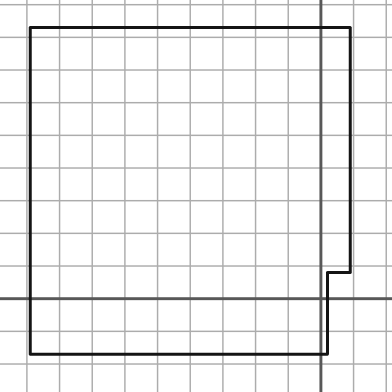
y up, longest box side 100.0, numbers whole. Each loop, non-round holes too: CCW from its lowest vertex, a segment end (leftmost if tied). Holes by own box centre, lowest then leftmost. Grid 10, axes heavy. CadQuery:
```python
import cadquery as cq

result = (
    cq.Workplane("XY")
    .moveTo(-89.0, -17.0)
    .lineTo(2.0, -17.0)
    .lineTo(2.0, 8.0)
    .lineTo(9.0, 8.0)
    .lineTo(9.0, 83.0)
    .lineTo(-89.0, 83.0)
    .close()
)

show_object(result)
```